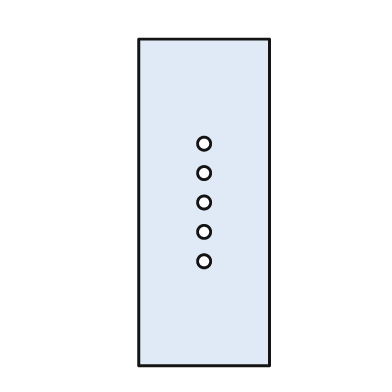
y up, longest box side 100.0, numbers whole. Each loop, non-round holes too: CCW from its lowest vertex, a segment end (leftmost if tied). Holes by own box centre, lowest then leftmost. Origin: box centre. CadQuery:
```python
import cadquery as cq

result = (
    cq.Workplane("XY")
    .moveTo(-20.0, -50.0)
    .lineTo(20.0, -50.0)
    .lineTo(20.0, 50.0)
    .lineTo(-20.0, 50.0)
    .close()
    .moveTo(0.0, -18.0)
    .circle(2.0)
    .moveTo(0.0, -9.0)
    .circle(2.0)
    .moveTo(0.0, 0.0)
    .circle(2.0)
    .moveTo(0.0, 9.0)
    .circle(2.0)
    .moveTo(0.0, 18.0)
    .circle(2.0)
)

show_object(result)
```